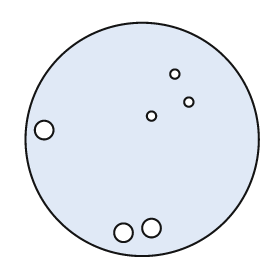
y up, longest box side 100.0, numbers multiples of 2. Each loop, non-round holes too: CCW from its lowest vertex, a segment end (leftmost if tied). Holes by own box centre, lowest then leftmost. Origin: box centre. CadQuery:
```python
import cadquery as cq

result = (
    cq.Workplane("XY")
    .moveTo(0.0, 0.0)
    .circle(50.0)
    .moveTo(-8.0, -40.0)
    .circle(4.0)
    .moveTo(4.0, -38.0)
    .circle(4.0)
    .moveTo(-42.0, 4.0)
    .circle(4.0)
    .moveTo(4.0, 10.0)
    .circle(2.0)
    .moveTo(20.0, 16.0)
    .circle(2.0)
    .moveTo(14.0, 28.0)
    .circle(2.0)
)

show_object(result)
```